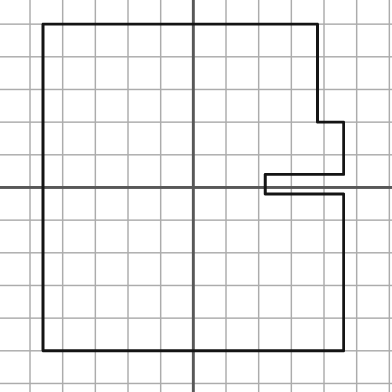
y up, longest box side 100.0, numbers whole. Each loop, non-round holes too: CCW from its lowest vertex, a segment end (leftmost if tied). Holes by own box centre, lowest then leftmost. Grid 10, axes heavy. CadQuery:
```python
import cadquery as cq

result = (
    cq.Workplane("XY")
    .moveTo(-46.0, -50.0)
    .lineTo(46.0, -50.0)
    .lineTo(46.0, -2.0)
    .lineTo(22.0, -2.0)
    .lineTo(22.0, 4.0)
    .lineTo(46.0, 4.0)
    .lineTo(46.0, 20.0)
    .lineTo(38.0, 20.0)
    .lineTo(38.0, 50.0)
    .lineTo(-46.0, 50.0)
    .close()
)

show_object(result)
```